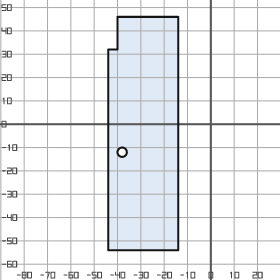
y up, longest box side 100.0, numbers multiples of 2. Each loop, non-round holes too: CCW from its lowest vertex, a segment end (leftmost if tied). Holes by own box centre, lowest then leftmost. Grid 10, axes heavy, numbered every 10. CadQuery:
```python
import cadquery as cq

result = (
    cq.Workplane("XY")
    .moveTo(-44.0, -54.0)
    .lineTo(-14.0, -54.0)
    .lineTo(-14.0, 46.0)
    .lineTo(-40.0, 46.0)
    .lineTo(-40.0, 32.0)
    .lineTo(-44.0, 32.0)
    .close()
    .moveTo(-38.0, -12.0)
    .circle(2.0)
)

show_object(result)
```